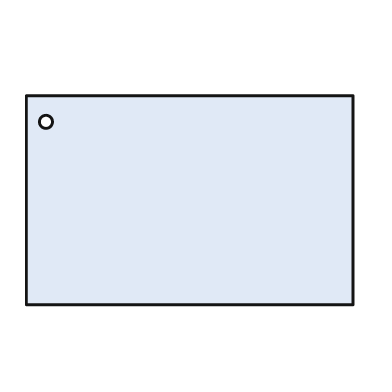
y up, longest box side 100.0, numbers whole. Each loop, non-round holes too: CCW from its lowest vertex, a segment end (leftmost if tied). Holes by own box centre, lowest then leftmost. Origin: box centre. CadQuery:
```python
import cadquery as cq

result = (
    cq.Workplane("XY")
    .moveTo(-50.0, -32.0)
    .lineTo(50.0, -32.0)
    .lineTo(50.0, 32.0)
    .lineTo(-50.0, 32.0)
    .close()
    .moveTo(-44.0, 24.0)
    .circle(2.0)
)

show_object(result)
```